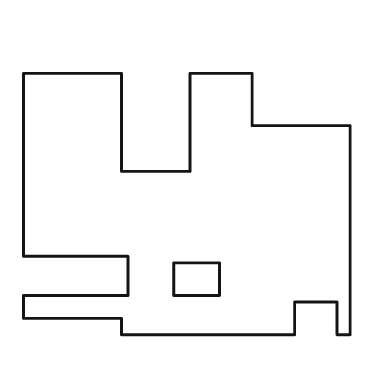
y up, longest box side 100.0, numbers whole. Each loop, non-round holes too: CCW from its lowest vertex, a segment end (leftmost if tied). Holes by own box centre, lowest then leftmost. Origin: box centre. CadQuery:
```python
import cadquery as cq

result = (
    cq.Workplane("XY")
    .moveTo(-20.0, -40.0)
    .lineTo(33.0, -40.0)
    .lineTo(33.0, -30.0)
    .lineTo(46.0, -30.0)
    .lineTo(46.0, -40.0)
    .lineTo(50.0, -40.0)
    .lineTo(50.0, 24.0)
    .lineTo(20.0, 24.0)
    .lineTo(20.0, 40.0)
    .lineTo(1.0, 40.0)
    .lineTo(1.0, 10.0)
    .lineTo(-20.0, 10.0)
    .lineTo(-20.0, 40.0)
    .lineTo(-50.0, 40.0)
    .lineTo(-50.0, -16.0)
    .lineTo(-18.0, -16.0)
    .lineTo(-18.0, -28.0)
    .lineTo(-50.0, -28.0)
    .lineTo(-50.0, -35.0)
    .lineTo(-20.0, -35.0)
    .close()
    .moveTo(-4.0, -28.0)
    .lineTo(10.0, -28.0)
    .lineTo(10.0, -18.0)
    .lineTo(-4.0, -18.0)
    .close()
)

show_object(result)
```